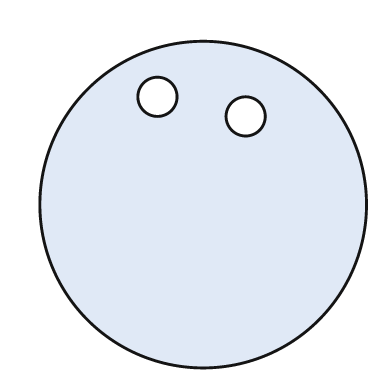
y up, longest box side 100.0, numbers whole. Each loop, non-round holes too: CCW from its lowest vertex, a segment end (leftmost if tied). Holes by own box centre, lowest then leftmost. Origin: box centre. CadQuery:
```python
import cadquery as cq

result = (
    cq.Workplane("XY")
    .moveTo(0.0, 0.0)
    .circle(50.0)
    .moveTo(13.0, 27.0)
    .circle(6.0)
    .moveTo(-14.0, 33.0)
    .circle(6.0)
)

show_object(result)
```